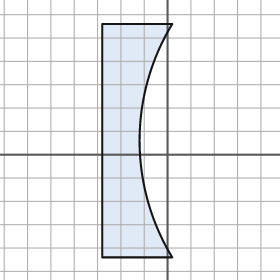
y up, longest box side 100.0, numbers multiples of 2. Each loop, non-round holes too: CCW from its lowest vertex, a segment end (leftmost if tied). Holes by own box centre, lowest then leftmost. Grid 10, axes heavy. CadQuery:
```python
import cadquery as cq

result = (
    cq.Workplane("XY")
    .moveTo(-28.0, -44.0)
    .lineTo(2.0, -44.0)
    .threePointArc((-12.0, 6.0), (2.0, 56.0))
    .lineTo(-28.0, 56.0)
    .close()
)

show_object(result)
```